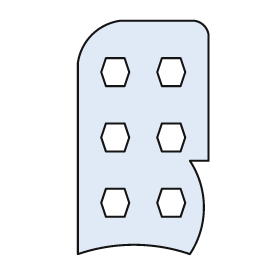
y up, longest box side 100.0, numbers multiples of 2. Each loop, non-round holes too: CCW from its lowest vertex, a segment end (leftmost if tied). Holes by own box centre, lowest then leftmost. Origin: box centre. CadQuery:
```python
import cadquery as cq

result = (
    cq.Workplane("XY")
    .moveTo(-28.0, -50.0)
    .threePointArc((-4.0, -46.0), (20.0, -50.0))
    .threePointArc((26.0, -30.0), (20.0, -10.0))
    .lineTo(28.0, -10.0)
    .lineTo(28.0, 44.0)
    .threePointArc((26.0, 48.0), (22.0, 50.0))
    .lineTo(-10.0, 50.0)
    .threePointArc((-22.0, 44.0), (-28.0, 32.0))
    .close()
    .moveTo(-16.0, -34.0)
    .lineTo(-8.0, -34.0)
    .lineTo(-6.0, -28.0)
    .lineTo(-8.0, -22.0)
    .lineTo(-16.0, -22.0)
    .lineTo(-18.0, -28.0)
    .close()
    .moveTo(8.0, -34.0)
    .lineTo(16.0, -34.0)
    .lineTo(18.0, -28.0)
    .lineTo(16.0, -22.0)
    .lineTo(8.0, -22.0)
    .lineTo(6.0, -28.0)
    .close()
    .moveTo(-16.0, -6.0)
    .lineTo(-8.0, -6.0)
    .lineTo(-6.0, 0.0)
    .lineTo(-8.0, 6.0)
    .lineTo(-16.0, 6.0)
    .lineTo(-18.0, 0.0)
    .close()
    .moveTo(8.0, -6.0)
    .lineTo(16.0, -6.0)
    .lineTo(18.0, 0.0)
    .lineTo(16.0, 6.0)
    .lineTo(8.0, 6.0)
    .lineTo(6.0, 0.0)
    .close()
    .moveTo(-16.0, 22.0)
    .lineTo(-8.0, 22.0)
    .lineTo(-6.0, 28.0)
    .lineTo(-8.0, 34.0)
    .lineTo(-16.0, 34.0)
    .lineTo(-18.0, 28.0)
    .close()
    .moveTo(8.0, 22.0)
    .lineTo(16.0, 22.0)
    .lineTo(18.0, 28.0)
    .lineTo(16.0, 34.0)
    .lineTo(8.0, 34.0)
    .lineTo(6.0, 28.0)
    .close()
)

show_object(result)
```